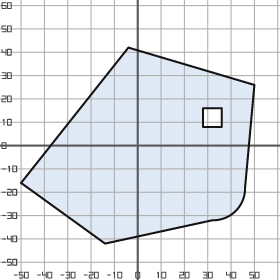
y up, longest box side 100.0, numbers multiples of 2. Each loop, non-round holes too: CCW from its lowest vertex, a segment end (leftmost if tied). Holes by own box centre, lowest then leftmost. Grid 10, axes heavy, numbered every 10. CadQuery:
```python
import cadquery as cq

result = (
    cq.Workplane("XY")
    .moveTo(-14.0, -42.0)
    .lineTo(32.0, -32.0)
    .threePointArc((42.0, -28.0), (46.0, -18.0))
    .lineTo(50.0, 26.0)
    .lineTo(-4.0, 42.0)
    .lineTo(-50.0, -16.0)
    .close()
    .moveTo(28.0, 8.0)
    .lineTo(36.0, 8.0)
    .lineTo(36.0, 16.0)
    .lineTo(28.0, 16.0)
    .close()
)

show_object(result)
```